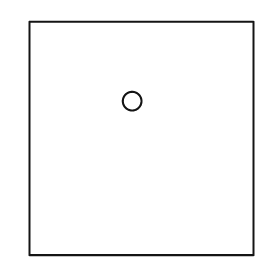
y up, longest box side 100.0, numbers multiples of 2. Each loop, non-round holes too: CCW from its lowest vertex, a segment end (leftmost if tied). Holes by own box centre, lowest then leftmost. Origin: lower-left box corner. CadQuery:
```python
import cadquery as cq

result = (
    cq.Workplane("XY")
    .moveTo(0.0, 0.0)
    .lineTo(96.0, 0.0)
    .lineTo(96.0, 100.0)
    .lineTo(0.0, 100.0)
    .close()
    .moveTo(44.0, 66.0)
    .circle(4.0)
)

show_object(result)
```